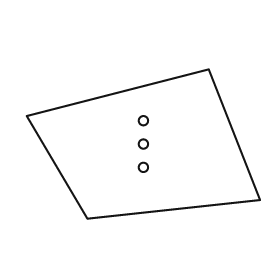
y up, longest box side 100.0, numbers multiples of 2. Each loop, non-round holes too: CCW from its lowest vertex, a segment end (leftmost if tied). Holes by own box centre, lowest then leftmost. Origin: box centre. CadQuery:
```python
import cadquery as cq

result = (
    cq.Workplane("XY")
    .moveTo(-24.0, -32.0)
    .lineTo(50.0, -24.0)
    .lineTo(28.0, 32.0)
    .lineTo(-50.0, 12.0)
    .close()
    .moveTo(0.0, -10.0)
    .circle(2.0)
    .moveTo(0.0, 0.0)
    .circle(2.0)
    .moveTo(0.0, 10.0)
    .circle(2.0)
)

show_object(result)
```